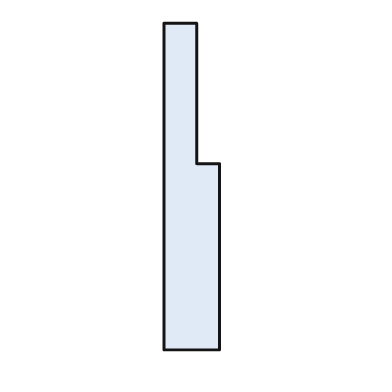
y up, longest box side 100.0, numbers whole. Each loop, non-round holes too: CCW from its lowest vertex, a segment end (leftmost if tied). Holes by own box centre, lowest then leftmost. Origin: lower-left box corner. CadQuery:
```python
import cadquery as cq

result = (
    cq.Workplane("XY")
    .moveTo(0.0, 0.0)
    .lineTo(17.0, 0.0)
    .lineTo(17.0, 57.0)
    .lineTo(10.0, 57.0)
    .lineTo(10.0, 100.0)
    .lineTo(0.0, 100.0)
    .close()
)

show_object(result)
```